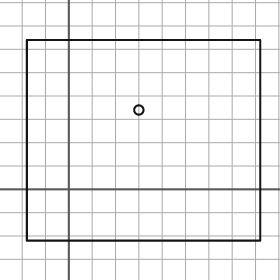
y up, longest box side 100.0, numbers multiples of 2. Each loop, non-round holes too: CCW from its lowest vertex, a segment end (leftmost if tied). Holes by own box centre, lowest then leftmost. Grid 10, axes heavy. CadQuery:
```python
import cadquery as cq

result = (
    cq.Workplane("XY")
    .moveTo(-18.0, -22.0)
    .lineTo(82.0, -22.0)
    .lineTo(82.0, 64.0)
    .lineTo(-18.0, 64.0)
    .close()
    .moveTo(30.0, 34.0)
    .circle(2.0)
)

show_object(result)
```